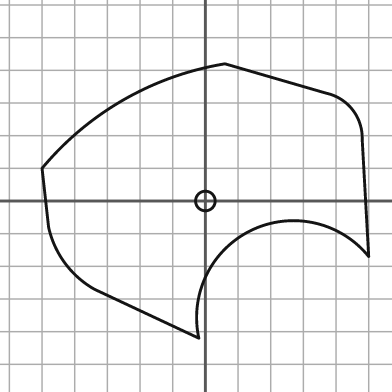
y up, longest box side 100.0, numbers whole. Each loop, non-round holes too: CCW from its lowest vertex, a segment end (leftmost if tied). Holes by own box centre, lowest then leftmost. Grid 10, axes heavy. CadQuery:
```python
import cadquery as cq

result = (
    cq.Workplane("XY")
    .moveTo(-2.0, -42.0)
    .threePointArc((14.0, -9.0), (50.0, -17.0))
    .lineTo(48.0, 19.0)
    .threePointArc((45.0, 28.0), (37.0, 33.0))
    .lineTo(6.0, 42.0)
    .threePointArc((-25.0, 31.0), (-50.0, 10.0))
    .lineTo(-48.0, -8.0)
    .threePointArc((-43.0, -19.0), (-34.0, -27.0))
    .close()
    .moveTo(0.0, 0.0)
    .circle(3.0)
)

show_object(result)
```